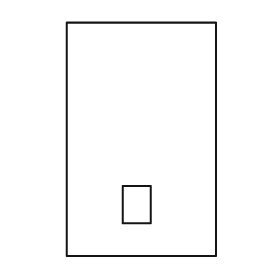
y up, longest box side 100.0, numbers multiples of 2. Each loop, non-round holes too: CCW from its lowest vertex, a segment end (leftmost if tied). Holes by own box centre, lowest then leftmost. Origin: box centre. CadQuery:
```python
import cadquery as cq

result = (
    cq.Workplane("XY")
    .moveTo(-32.0, -50.0)
    .lineTo(32.0, -50.0)
    .lineTo(32.0, 50.0)
    .lineTo(-32.0, 50.0)
    .close()
    .moveTo(-8.0, -36.0)
    .lineTo(4.0, -36.0)
    .lineTo(4.0, -20.0)
    .lineTo(-8.0, -20.0)
    .close()
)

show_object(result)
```